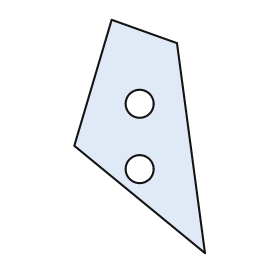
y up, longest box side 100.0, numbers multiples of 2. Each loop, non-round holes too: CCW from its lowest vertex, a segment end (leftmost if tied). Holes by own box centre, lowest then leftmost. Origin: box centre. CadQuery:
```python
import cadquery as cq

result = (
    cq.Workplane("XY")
    .moveTo(28.0, -50.0)
    .lineTo(16.0, 40.0)
    .lineTo(-12.0, 50.0)
    .lineTo(-28.0, -4.0)
    .close()
    .moveTo(0.0, -14.0)
    .circle(6.0)
    .moveTo(0.0, 14.0)
    .circle(6.0)
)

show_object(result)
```